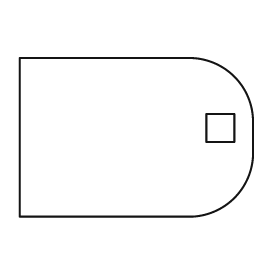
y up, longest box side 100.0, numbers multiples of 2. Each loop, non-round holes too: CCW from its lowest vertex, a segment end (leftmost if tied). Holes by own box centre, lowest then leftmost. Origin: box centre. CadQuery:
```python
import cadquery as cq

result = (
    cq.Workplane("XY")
    .moveTo(-50.0, -34.0)
    .lineTo(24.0, -34.0)
    .threePointArc((42.0, -26.0), (50.0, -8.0))
    .lineTo(50.0, 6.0)
    .threePointArc((42.0, 26.0), (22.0, 34.0))
    .lineTo(-50.0, 34.0)
    .close()
    .moveTo(30.0, -2.0)
    .lineTo(42.0, -2.0)
    .lineTo(42.0, 10.0)
    .lineTo(30.0, 10.0)
    .close()
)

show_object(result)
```